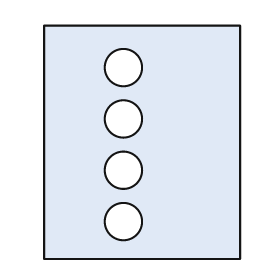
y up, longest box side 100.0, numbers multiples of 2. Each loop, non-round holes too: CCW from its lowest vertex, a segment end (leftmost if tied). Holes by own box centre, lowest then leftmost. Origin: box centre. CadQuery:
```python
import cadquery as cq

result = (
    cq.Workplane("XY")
    .moveTo(-42.0, -50.0)
    .lineTo(42.0, -50.0)
    .lineTo(42.0, 50.0)
    .lineTo(-42.0, 50.0)
    .close()
    .moveTo(-8.0, -34.0)
    .circle(8.0)
    .moveTo(-8.0, -12.0)
    .circle(8.0)
    .moveTo(-8.0, 10.0)
    .circle(8.0)
    .moveTo(-8.0, 32.0)
    .circle(8.0)
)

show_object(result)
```